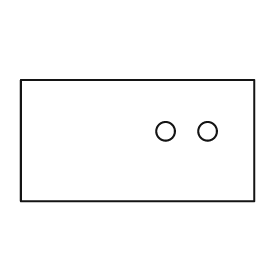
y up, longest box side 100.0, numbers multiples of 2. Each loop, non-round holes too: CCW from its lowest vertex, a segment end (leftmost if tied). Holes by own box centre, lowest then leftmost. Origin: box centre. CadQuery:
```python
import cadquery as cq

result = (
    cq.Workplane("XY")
    .moveTo(-50.0, -26.0)
    .lineTo(50.0, -26.0)
    .lineTo(50.0, 26.0)
    .lineTo(-50.0, 26.0)
    .close()
    .moveTo(12.0, 4.0)
    .circle(4.0)
    .moveTo(30.0, 4.0)
    .circle(4.0)
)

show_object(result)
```